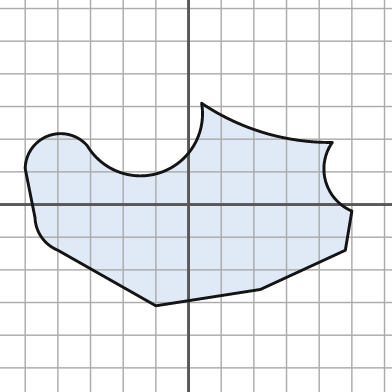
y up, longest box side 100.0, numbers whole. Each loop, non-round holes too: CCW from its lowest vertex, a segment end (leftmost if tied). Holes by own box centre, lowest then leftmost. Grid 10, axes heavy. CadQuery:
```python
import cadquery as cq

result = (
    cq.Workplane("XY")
    .moveTo(-10.0, -31.0)
    .lineTo(22.0, -26.0)
    .lineTo(48.0, -14.0)
    .lineTo(50.0, -2.0)
    .threePointArc((42.0, 7.0), (44.0, 19.0))
    .threePointArc((23.0, 22.0), (4.0, 31.0))
    .threePointArc((-8.0, 10.0), (-31.0, 18.0))
    .threePointArc((-43.0, 21.0), (-50.0, 11.0))
    .lineTo(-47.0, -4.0)
    .threePointArc((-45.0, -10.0), (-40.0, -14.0))
    .close()
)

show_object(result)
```